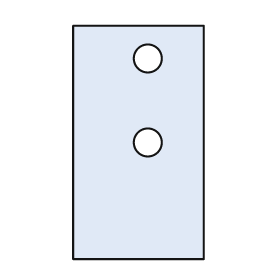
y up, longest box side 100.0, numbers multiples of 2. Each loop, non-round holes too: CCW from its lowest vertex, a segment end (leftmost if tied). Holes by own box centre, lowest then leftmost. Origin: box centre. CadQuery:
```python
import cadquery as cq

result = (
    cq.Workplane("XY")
    .moveTo(-28.0, -50.0)
    .lineTo(28.0, -50.0)
    .lineTo(28.0, 50.0)
    .lineTo(-28.0, 50.0)
    .close()
    .moveTo(4.0, 0.0)
    .circle(6.0)
    .moveTo(4.0, 36.0)
    .circle(6.0)
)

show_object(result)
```